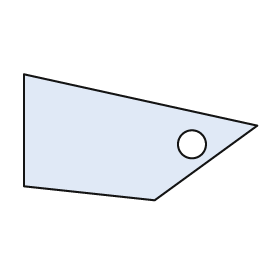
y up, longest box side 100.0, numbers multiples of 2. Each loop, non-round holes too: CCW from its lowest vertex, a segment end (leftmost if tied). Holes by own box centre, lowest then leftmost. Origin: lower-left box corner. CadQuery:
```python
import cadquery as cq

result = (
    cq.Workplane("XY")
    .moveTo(56.0, 0.0)
    .lineTo(100.0, 32.0)
    .lineTo(0.0, 54.0)
    .lineTo(0.0, 6.0)
    .close()
    .moveTo(72.0, 24.0)
    .circle(6.0)
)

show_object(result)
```